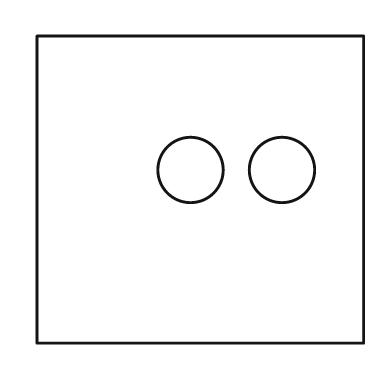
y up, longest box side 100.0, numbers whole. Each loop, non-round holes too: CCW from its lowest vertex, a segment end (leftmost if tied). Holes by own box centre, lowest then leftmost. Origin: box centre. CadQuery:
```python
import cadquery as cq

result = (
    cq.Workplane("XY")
    .moveTo(-50.0, -47.0)
    .lineTo(50.0, -47.0)
    .lineTo(50.0, 47.0)
    .lineTo(-50.0, 47.0)
    .close()
    .moveTo(-3.0, 6.0)
    .circle(10.0)
    .moveTo(25.0, 6.0)
    .circle(10.0)
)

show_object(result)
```